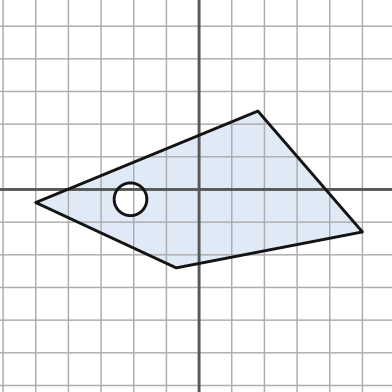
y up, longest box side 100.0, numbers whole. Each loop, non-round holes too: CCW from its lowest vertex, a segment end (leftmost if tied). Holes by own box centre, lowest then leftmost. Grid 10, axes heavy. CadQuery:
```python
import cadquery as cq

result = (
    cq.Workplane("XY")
    .moveTo(-7.0, -24.0)
    .lineTo(50.0, -13.0)
    .lineTo(18.0, 24.0)
    .lineTo(-50.0, -4.0)
    .close()
    .moveTo(-21.0, -3.0)
    .circle(5.0)
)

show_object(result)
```